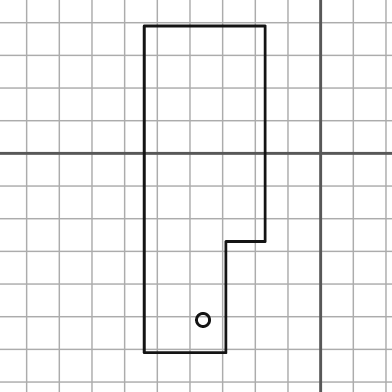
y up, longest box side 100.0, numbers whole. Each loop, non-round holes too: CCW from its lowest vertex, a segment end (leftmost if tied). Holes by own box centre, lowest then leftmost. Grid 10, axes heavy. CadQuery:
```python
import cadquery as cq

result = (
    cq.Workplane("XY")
    .moveTo(-54.0, -61.0)
    .lineTo(-29.0, -61.0)
    .lineTo(-29.0, -27.0)
    .lineTo(-17.0, -27.0)
    .lineTo(-17.0, 39.0)
    .lineTo(-54.0, 39.0)
    .close()
    .moveTo(-36.0, -51.0)
    .circle(2.0)
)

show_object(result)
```